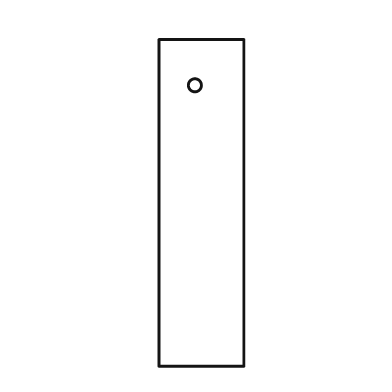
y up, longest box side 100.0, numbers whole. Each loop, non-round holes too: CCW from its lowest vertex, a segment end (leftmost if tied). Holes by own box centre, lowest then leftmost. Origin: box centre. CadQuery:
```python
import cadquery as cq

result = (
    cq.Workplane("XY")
    .moveTo(-13.0, -50.0)
    .lineTo(13.0, -50.0)
    .lineTo(13.0, 50.0)
    .lineTo(-13.0, 50.0)
    .close()
    .moveTo(-2.0, 36.0)
    .circle(2.0)
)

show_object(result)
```